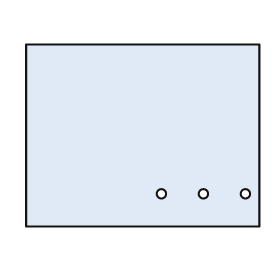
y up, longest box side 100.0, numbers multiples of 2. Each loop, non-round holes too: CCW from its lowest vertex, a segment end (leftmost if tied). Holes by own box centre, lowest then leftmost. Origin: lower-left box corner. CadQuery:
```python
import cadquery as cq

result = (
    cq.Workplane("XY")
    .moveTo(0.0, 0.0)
    .lineTo(100.0, 0.0)
    .lineTo(100.0, 78.0)
    .lineTo(0.0, 78.0)
    .close()
    .moveTo(58.0, 14.0)
    .circle(2.0)
    .moveTo(76.0, 14.0)
    .circle(2.0)
    .moveTo(94.0, 14.0)
    .circle(2.0)
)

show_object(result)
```